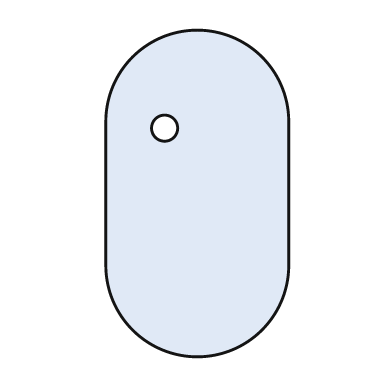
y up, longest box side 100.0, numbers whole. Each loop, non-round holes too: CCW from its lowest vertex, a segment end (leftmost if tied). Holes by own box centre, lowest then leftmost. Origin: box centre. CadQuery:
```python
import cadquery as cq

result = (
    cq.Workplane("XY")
    .moveTo(-28.0, -22.0)
    .threePointArc((0.0, -50.0), (28.0, -22.0))
    .lineTo(28.0, 22.0)
    .threePointArc((0.0, 50.0), (-28.0, 22.0))
    .close()
    .moveTo(-10.0, 20.0)
    .circle(4.0)
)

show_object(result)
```